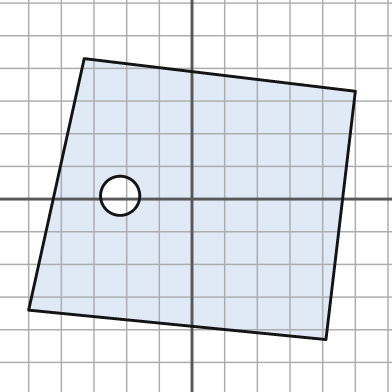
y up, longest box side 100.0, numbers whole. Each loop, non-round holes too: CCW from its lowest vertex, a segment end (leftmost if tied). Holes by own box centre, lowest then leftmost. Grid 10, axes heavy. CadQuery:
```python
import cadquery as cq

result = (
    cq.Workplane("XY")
    .moveTo(41.0, -43.0)
    .lineTo(50.0, 33.0)
    .lineTo(-33.0, 43.0)
    .lineTo(-50.0, -34.0)
    .close()
    .moveTo(-22.0, 1.0)
    .circle(6.0)
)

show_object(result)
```